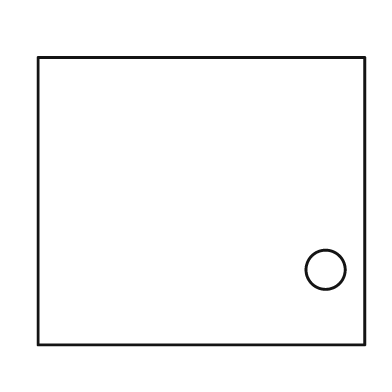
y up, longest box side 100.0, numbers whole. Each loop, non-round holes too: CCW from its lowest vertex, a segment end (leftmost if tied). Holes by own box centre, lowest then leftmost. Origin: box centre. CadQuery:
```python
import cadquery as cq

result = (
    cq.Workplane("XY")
    .moveTo(-50.0, -44.0)
    .lineTo(50.0, -44.0)
    .lineTo(50.0, 44.0)
    .lineTo(-50.0, 44.0)
    .close()
    .moveTo(38.0, -21.0)
    .circle(6.0)
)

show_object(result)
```